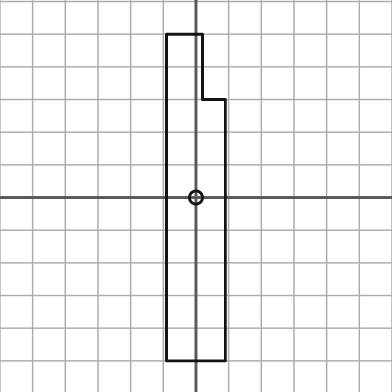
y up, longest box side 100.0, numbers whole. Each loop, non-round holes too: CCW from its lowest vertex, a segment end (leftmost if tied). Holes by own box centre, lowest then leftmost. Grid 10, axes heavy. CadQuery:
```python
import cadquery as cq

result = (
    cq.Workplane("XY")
    .moveTo(-9.0, -50.0)
    .lineTo(9.0, -50.0)
    .lineTo(9.0, 30.0)
    .lineTo(2.0, 30.0)
    .lineTo(2.0, 50.0)
    .lineTo(-9.0, 50.0)
    .close()
    .moveTo(0.0, 0.0)
    .circle(2.0)
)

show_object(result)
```